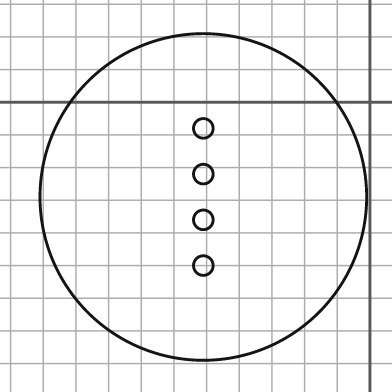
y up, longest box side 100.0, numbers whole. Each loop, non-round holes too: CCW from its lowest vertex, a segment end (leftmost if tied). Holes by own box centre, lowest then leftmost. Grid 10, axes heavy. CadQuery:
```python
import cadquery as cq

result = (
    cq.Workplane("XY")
    .moveTo(-51.0, -29.0)
    .circle(50.0)
    .moveTo(-51.0, -50.0)
    .circle(3.0)
    .moveTo(-51.0, -36.0)
    .circle(3.0)
    .moveTo(-51.0, -22.0)
    .circle(3.0)
    .moveTo(-51.0, -8.0)
    .circle(3.0)
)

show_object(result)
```